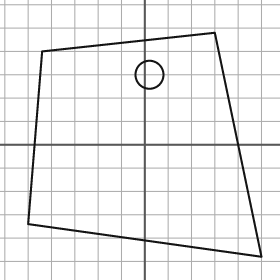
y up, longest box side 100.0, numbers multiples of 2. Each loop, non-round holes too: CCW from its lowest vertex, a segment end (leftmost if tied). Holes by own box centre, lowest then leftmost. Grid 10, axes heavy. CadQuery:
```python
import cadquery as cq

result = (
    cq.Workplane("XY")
    .moveTo(50.0, -48.0)
    .lineTo(30.0, 48.0)
    .lineTo(-44.0, 40.0)
    .lineTo(-50.0, -34.0)
    .close()
    .moveTo(2.0, 30.0)
    .circle(6.0)
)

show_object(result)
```